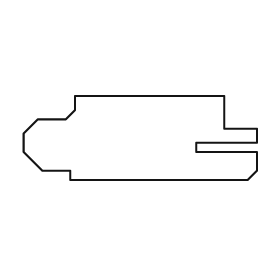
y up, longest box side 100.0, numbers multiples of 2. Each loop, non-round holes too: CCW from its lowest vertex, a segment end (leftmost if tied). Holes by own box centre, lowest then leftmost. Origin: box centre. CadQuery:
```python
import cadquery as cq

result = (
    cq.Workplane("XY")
    .moveTo(-30.0, -18.0)
    .lineTo(46.0, -18.0)
    .lineTo(50.0, -14.0)
    .lineTo(50.0, -6.0)
    .lineTo(24.0, -6.0)
    .lineTo(24.0, -2.0)
    .lineTo(50.0, -2.0)
    .lineTo(50.0, 4.0)
    .lineTo(36.0, 4.0)
    .lineTo(36.0, 18.0)
    .lineTo(-28.0, 18.0)
    .lineTo(-28.0, 12.0)
    .lineTo(-32.0, 8.0)
    .lineTo(-44.0, 8.0)
    .lineTo(-50.0, 2.0)
    .lineTo(-50.0, -6.0)
    .lineTo(-42.0, -14.0)
    .lineTo(-30.0, -14.0)
    .close()
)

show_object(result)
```